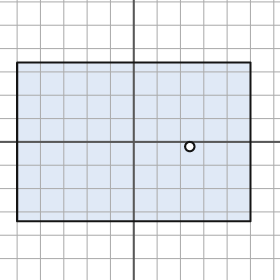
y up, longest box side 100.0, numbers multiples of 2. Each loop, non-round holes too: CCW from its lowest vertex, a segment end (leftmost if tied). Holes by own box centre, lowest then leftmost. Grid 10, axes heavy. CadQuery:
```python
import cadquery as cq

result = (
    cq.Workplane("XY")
    .moveTo(-50.0, -34.0)
    .lineTo(50.0, -34.0)
    .lineTo(50.0, 34.0)
    .lineTo(-50.0, 34.0)
    .close()
    .moveTo(24.0, -2.0)
    .circle(2.0)
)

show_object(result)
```